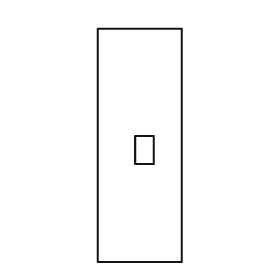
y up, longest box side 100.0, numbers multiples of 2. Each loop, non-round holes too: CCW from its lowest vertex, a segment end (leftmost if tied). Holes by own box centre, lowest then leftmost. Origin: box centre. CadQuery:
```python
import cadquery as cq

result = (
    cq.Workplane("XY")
    .moveTo(-18.0, -50.0)
    .lineTo(18.0, -50.0)
    .lineTo(18.0, 50.0)
    .lineTo(-18.0, 50.0)
    .close()
    .moveTo(-2.0, -8.0)
    .lineTo(6.0, -8.0)
    .lineTo(6.0, 4.0)
    .lineTo(-2.0, 4.0)
    .close()
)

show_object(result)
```